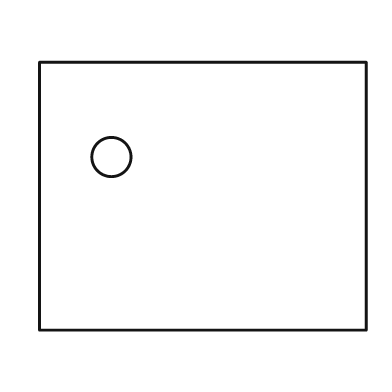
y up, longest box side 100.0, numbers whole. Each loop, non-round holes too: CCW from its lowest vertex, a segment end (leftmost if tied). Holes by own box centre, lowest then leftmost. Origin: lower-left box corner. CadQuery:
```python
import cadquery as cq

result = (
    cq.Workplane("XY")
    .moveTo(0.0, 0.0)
    .lineTo(100.0, 0.0)
    .lineTo(100.0, 82.0)
    .lineTo(0.0, 82.0)
    .close()
    .moveTo(22.0, 53.0)
    .circle(6.0)
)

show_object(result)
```